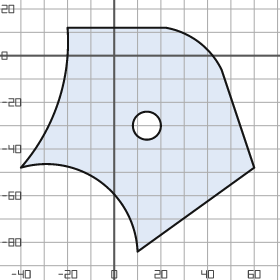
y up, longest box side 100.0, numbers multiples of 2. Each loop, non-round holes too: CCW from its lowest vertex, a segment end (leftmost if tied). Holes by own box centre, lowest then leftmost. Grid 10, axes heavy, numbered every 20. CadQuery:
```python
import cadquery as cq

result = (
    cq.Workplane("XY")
    .moveTo(10.0, -84.0)
    .lineTo(60.0, -48.0)
    .lineTo(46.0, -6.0)
    .threePointArc((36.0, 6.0), (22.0, 12.0))
    .lineTo(-20.0, 12.0)
    .threePointArc((-24.0, -20.0), (-40.0, -48.0))
    .threePointArc((-6.0, -54.0), (10.0, -84.0))
    .close()
    .moveTo(14.0, -30.0)
    .circle(6.0)
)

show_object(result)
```